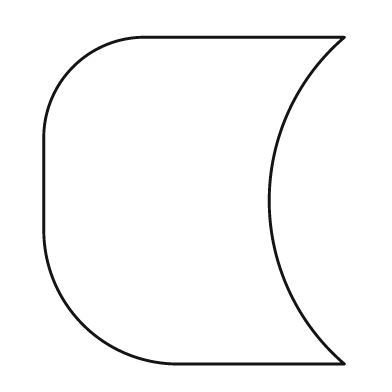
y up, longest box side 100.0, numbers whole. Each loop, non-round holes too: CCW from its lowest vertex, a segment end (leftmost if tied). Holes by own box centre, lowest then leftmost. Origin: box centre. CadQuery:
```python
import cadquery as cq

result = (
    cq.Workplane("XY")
    .moveTo(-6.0, -50.0)
    .lineTo(46.0, -50.0)
    .threePointArc((23.0, 0.0), (46.0, 50.0))
    .lineTo(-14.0, 50.0)
    .threePointArc((-37.0, 41.0), (-46.0, 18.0))
    .lineTo(-46.0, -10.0)
    .threePointArc((-34.0, -38.0), (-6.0, -50.0))
    .close()
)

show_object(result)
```